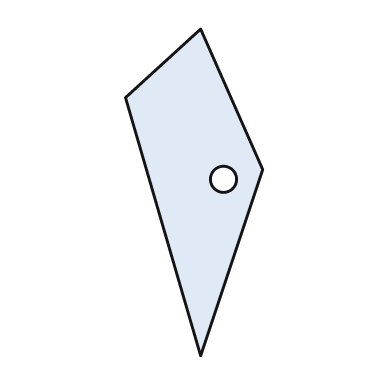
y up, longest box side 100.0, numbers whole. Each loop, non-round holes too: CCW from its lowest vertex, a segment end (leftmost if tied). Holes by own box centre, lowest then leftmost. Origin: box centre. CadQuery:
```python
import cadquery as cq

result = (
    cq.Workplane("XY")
    .moveTo(2.0, -50.0)
    .lineTo(21.0, 7.0)
    .lineTo(2.0, 50.0)
    .lineTo(-21.0, 29.0)
    .close()
    .moveTo(9.0, 4.0)
    .circle(4.0)
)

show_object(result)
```